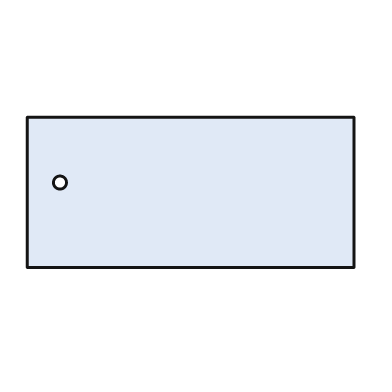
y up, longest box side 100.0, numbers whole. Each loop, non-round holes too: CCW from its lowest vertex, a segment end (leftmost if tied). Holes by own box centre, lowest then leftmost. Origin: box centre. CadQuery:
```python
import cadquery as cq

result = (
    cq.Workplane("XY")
    .moveTo(-50.0, -23.0)
    .lineTo(50.0, -23.0)
    .lineTo(50.0, 23.0)
    .lineTo(-50.0, 23.0)
    .close()
    .moveTo(-40.0, 3.0)
    .circle(2.0)
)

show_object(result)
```